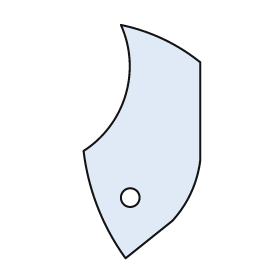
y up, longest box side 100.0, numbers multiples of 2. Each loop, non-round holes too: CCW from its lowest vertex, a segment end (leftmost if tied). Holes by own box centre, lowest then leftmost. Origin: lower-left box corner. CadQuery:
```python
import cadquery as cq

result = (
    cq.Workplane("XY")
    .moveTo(18.0, 0.0)
    .lineTo(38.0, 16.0)
    .threePointArc((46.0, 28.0), (50.0, 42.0))
    .lineTo(50.0, 84.0)
    .threePointArc((34.0, 94.0), (16.0, 100.0))
    .threePointArc((18.0, 70.0), (0.0, 46.0))
    .threePointArc((6.0, 22.0), (18.0, 0.0))
    .close()
    .moveTo(20.0, 26.0)
    .circle(4.0)
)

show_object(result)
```